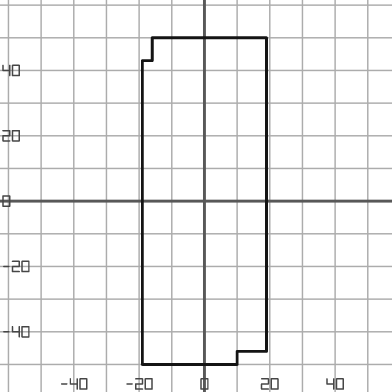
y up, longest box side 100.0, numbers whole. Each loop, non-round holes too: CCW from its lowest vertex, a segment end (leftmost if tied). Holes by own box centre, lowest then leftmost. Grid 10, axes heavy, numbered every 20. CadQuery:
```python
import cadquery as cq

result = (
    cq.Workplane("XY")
    .moveTo(-19.0, -50.0)
    .lineTo(10.0, -50.0)
    .lineTo(10.0, -46.0)
    .lineTo(19.0, -46.0)
    .lineTo(19.0, 50.0)
    .lineTo(-16.0, 50.0)
    .lineTo(-16.0, 43.0)
    .lineTo(-19.0, 43.0)
    .close()
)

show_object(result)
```